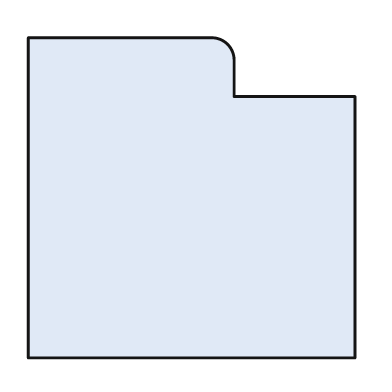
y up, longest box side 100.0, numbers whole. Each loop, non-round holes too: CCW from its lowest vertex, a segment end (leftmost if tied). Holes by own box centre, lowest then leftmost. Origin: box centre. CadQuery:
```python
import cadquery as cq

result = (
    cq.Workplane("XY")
    .moveTo(-50.0, -49.0)
    .lineTo(50.0, -49.0)
    .lineTo(50.0, 31.0)
    .lineTo(13.0, 31.0)
    .lineTo(13.0, 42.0)
    .threePointArc((11.0, 47.0), (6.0, 49.0))
    .lineTo(-50.0, 49.0)
    .close()
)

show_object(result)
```